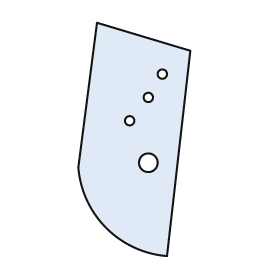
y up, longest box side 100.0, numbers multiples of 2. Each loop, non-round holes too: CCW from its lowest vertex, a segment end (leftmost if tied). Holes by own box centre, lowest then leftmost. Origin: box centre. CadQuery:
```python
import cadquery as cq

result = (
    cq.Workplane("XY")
    .moveTo(14.0, -50.0)
    .lineTo(24.0, 38.0)
    .lineTo(-16.0, 50.0)
    .lineTo(-24.0, -12.0)
    .threePointArc((-12.0, -38.0), (14.0, -50.0))
    .close()
    .moveTo(6.0, -10.0)
    .circle(4.0)
    .moveTo(-2.0, 8.0)
    .circle(2.0)
    .moveTo(6.0, 18.0)
    .circle(2.0)
    .moveTo(12.0, 28.0)
    .circle(2.0)
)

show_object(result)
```